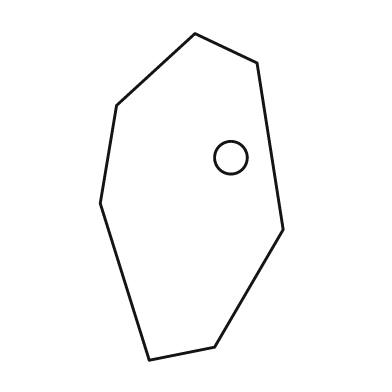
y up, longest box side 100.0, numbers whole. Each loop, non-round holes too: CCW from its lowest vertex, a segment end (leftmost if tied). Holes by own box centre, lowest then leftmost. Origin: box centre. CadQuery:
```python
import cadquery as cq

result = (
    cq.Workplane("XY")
    .moveTo(-13.0, -50.0)
    .lineTo(7.0, -46.0)
    .lineTo(28.0, -10.0)
    .lineTo(20.0, 41.0)
    .lineTo(1.0, 50.0)
    .lineTo(-23.0, 28.0)
    .lineTo(-28.0, -2.0)
    .close()
    .moveTo(12.0, 12.0)
    .circle(5.0)
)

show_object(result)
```